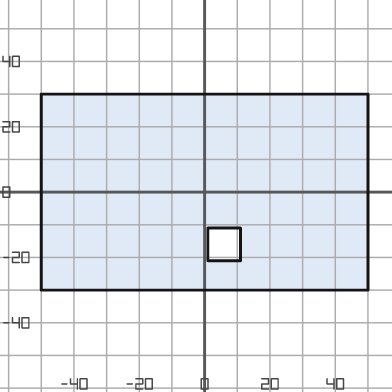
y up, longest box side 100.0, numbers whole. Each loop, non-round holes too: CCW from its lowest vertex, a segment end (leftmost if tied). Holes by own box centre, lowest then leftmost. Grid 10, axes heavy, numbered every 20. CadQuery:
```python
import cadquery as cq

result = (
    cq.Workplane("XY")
    .moveTo(-50.0, -30.0)
    .lineTo(50.0, -30.0)
    .lineTo(50.0, 30.0)
    .lineTo(-50.0, 30.0)
    .close()
    .moveTo(1.0, -21.0)
    .lineTo(11.0, -21.0)
    .lineTo(11.0, -11.0)
    .lineTo(1.0, -11.0)
    .close()
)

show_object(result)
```